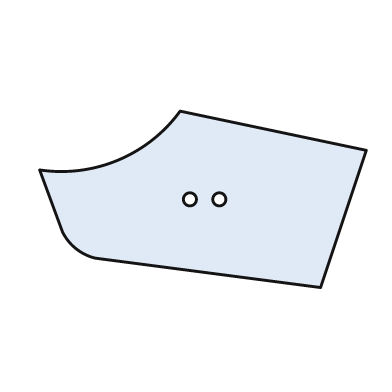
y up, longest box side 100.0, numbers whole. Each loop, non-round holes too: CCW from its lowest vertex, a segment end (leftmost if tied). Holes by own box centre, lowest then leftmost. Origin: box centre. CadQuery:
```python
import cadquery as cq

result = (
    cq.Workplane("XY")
    .moveTo(36.0, -27.0)
    .lineTo(50.0, 15.0)
    .lineTo(-7.0, 27.0)
    .threePointArc((-26.0, 12.0), (-50.0, 9.0))
    .lineTo(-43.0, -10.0)
    .threePointArc((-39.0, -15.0), (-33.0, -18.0))
    .close()
    .moveTo(-4.0, 0.0)
    .circle(2.0)
    .moveTo(5.0, 0.0)
    .circle(2.0)
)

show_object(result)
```